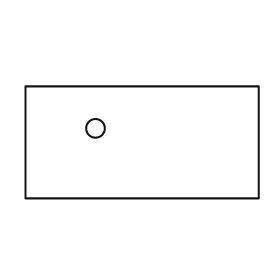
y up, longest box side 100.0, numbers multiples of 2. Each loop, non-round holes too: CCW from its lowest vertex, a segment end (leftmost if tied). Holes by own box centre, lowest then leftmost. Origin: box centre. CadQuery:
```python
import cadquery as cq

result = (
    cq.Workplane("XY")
    .moveTo(-50.0, -24.0)
    .lineTo(50.0, -24.0)
    .lineTo(50.0, 24.0)
    .lineTo(-50.0, 24.0)
    .close()
    .moveTo(-20.0, 6.0)
    .circle(4.0)
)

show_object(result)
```